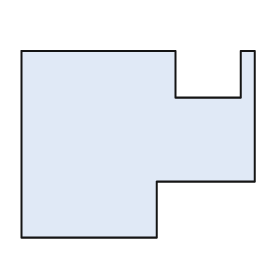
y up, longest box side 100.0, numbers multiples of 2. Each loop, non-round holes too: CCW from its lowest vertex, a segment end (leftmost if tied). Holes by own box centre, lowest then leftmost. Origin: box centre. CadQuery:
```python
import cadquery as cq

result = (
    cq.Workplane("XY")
    .moveTo(-50.0, -40.0)
    .lineTo(8.0, -40.0)
    .lineTo(8.0, -16.0)
    .lineTo(50.0, -16.0)
    .lineTo(50.0, 40.0)
    .lineTo(44.0, 40.0)
    .lineTo(44.0, 20.0)
    .lineTo(16.0, 20.0)
    .lineTo(16.0, 40.0)
    .lineTo(-50.0, 40.0)
    .close()
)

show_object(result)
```